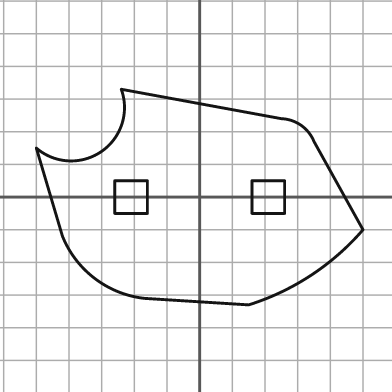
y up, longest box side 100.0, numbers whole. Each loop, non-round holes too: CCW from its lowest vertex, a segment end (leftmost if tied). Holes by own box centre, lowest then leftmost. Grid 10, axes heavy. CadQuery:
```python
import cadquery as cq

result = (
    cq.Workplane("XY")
    .moveTo(15.0, -33.0)
    .threePointArc((34.0, -24.0), (50.0, -10.0))
    .lineTo(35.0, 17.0)
    .threePointArc((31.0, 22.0), (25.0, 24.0))
    .lineTo(-24.0, 33.0)
    .threePointArc((-30.0, 14.0), (-50.0, 15.0))
    .lineTo(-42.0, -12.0)
    .threePointArc((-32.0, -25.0), (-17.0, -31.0))
    .close()
    .moveTo(-26.0, -5.0)
    .lineTo(-16.0, -5.0)
    .lineTo(-16.0, 5.0)
    .lineTo(-26.0, 5.0)
    .close()
    .moveTo(16.0, -5.0)
    .lineTo(26.0, -5.0)
    .lineTo(26.0, 5.0)
    .lineTo(16.0, 5.0)
    .close()
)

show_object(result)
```